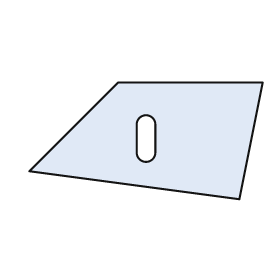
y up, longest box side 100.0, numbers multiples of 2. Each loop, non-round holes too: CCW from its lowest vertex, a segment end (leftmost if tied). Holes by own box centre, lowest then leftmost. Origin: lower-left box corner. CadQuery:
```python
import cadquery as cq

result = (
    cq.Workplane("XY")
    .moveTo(90.0, 0.0)
    .lineTo(100.0, 50.0)
    .lineTo(38.0, 50.0)
    .lineTo(0.0, 12.0)
    .close()
    .moveTo(46.0, 20.0)
    .threePointArc((50.0, 16.0), (54.0, 20.0))
    .lineTo(54.0, 32.0)
    .threePointArc((50.0, 36.0), (46.0, 32.0))
    .close()
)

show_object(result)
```